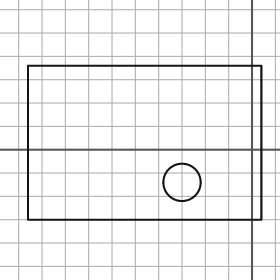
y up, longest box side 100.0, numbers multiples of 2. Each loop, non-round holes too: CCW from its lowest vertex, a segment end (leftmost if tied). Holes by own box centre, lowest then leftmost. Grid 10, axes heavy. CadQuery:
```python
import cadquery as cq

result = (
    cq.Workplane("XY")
    .moveTo(-96.0, -30.0)
    .lineTo(4.0, -30.0)
    .lineTo(4.0, 36.0)
    .lineTo(-96.0, 36.0)
    .close()
    .moveTo(-30.0, -14.0)
    .circle(8.0)
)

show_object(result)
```